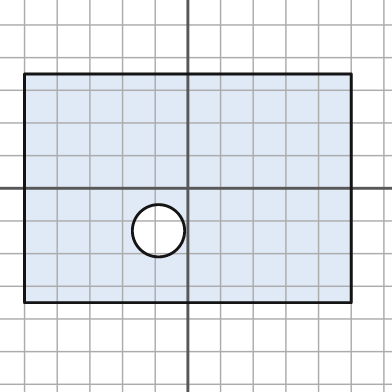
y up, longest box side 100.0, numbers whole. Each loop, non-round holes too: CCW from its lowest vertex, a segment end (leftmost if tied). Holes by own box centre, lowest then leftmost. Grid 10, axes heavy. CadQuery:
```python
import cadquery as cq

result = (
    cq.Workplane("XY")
    .moveTo(-50.0, -35.0)
    .lineTo(50.0, -35.0)
    .lineTo(50.0, 35.0)
    .lineTo(-50.0, 35.0)
    .close()
    .moveTo(-9.0, -13.0)
    .circle(8.0)
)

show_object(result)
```